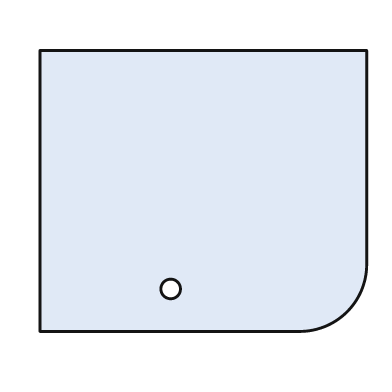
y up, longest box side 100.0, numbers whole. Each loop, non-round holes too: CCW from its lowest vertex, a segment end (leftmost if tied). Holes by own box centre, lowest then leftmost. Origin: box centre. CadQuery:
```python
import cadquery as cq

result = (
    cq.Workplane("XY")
    .moveTo(-50.0, -43.0)
    .lineTo(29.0, -43.0)
    .threePointArc((44.0, -37.0), (50.0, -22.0))
    .lineTo(50.0, 43.0)
    .lineTo(-50.0, 43.0)
    .close()
    .moveTo(-10.0, -30.0)
    .circle(3.0)
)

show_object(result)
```